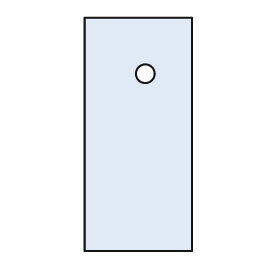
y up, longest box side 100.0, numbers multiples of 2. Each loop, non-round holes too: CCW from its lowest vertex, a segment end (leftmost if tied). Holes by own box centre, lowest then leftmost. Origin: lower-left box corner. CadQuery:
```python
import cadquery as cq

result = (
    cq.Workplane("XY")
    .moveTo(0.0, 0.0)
    .lineTo(46.0, 0.0)
    .lineTo(46.0, 100.0)
    .lineTo(0.0, 100.0)
    .close()
    .moveTo(26.0, 76.0)
    .circle(4.0)
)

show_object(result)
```